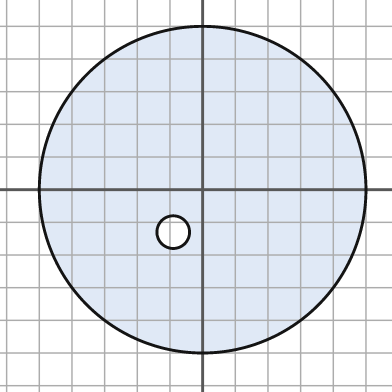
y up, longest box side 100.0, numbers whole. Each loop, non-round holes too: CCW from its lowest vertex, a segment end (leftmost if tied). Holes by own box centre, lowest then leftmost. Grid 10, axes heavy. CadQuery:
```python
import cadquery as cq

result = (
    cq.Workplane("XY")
    .moveTo(0.0, 0.0)
    .circle(50.0)
    .moveTo(-9.0, -13.0)
    .circle(5.0)
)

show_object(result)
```